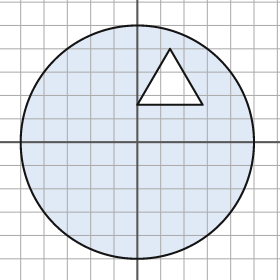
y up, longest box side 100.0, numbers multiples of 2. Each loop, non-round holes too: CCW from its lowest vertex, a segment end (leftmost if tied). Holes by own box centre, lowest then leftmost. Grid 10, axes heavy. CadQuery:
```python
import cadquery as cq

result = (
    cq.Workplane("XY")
    .moveTo(0.0, 0.0)
    .circle(50.0)
    .moveTo(0.0, 16.0)
    .lineTo(28.0, 16.0)
    .lineTo(14.0, 40.0)
    .close()
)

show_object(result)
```